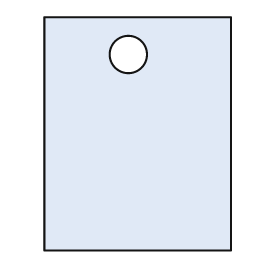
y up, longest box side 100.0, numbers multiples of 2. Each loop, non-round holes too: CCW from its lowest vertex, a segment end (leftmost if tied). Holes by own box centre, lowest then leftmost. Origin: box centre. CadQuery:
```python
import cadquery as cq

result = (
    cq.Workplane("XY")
    .moveTo(-40.0, -50.0)
    .lineTo(40.0, -50.0)
    .lineTo(40.0, 50.0)
    .lineTo(-40.0, 50.0)
    .close()
    .moveTo(-4.0, 34.0)
    .circle(8.0)
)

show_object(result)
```